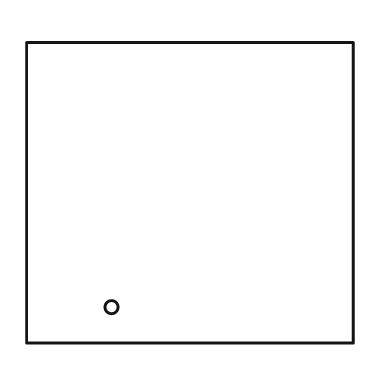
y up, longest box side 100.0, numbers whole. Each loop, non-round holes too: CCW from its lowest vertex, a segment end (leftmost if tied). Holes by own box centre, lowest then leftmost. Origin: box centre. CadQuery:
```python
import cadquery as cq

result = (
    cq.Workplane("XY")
    .moveTo(-50.0, -46.0)
    .lineTo(50.0, -46.0)
    .lineTo(50.0, 46.0)
    .lineTo(-50.0, 46.0)
    .close()
    .moveTo(-24.0, -35.0)
    .circle(2.0)
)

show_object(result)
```